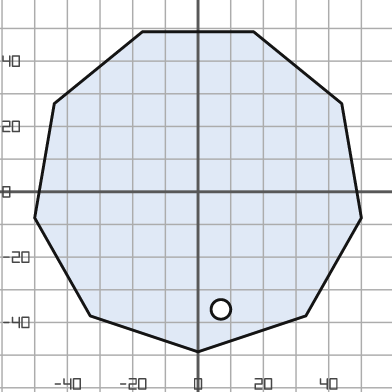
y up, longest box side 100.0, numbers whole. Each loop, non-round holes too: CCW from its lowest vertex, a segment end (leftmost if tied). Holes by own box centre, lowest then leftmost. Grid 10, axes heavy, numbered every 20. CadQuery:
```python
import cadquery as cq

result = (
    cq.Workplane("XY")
    .moveTo(0.0, -49.0)
    .lineTo(33.0, -38.0)
    .lineTo(50.0, -8.0)
    .lineTo(44.0, 27.0)
    .lineTo(17.0, 49.0)
    .lineTo(-17.0, 49.0)
    .lineTo(-44.0, 27.0)
    .lineTo(-50.0, -8.0)
    .lineTo(-33.0, -38.0)
    .close()
    .moveTo(7.0, -36.0)
    .circle(3.0)
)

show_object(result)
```